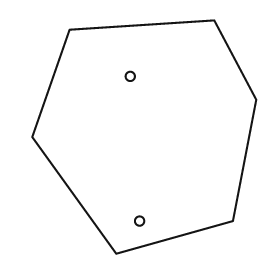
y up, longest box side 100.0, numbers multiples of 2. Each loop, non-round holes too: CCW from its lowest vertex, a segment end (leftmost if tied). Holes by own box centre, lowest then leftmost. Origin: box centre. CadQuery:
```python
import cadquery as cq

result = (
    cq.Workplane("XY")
    .moveTo(-12.0, -50.0)
    .lineTo(38.0, -36.0)
    .lineTo(48.0, 16.0)
    .lineTo(30.0, 50.0)
    .lineTo(-32.0, 46.0)
    .lineTo(-48.0, 0.0)
    .close()
    .moveTo(-2.0, -36.0)
    .circle(2.0)
    .moveTo(-6.0, 26.0)
    .circle(2.0)
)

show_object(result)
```